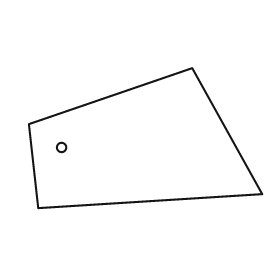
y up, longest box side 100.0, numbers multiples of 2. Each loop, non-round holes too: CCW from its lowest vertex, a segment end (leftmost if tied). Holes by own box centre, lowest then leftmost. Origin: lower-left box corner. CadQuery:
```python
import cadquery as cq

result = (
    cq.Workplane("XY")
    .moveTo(4.0, 0.0)
    .lineTo(100.0, 6.0)
    .lineTo(70.0, 60.0)
    .lineTo(0.0, 36.0)
    .close()
    .moveTo(14.0, 26.0)
    .circle(2.0)
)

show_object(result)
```